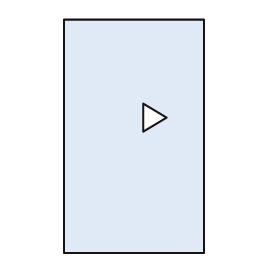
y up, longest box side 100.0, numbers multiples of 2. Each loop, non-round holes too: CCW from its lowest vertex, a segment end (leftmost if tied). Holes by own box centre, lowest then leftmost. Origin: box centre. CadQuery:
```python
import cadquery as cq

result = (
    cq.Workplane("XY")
    .moveTo(-30.0, -50.0)
    .lineTo(30.0, -50.0)
    .lineTo(30.0, 50.0)
    .lineTo(-30.0, 50.0)
    .close()
    .moveTo(4.0, 2.0)
    .lineTo(14.0, 8.0)
    .lineTo(4.0, 14.0)
    .close()
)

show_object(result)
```